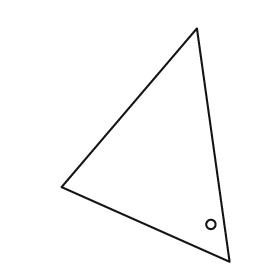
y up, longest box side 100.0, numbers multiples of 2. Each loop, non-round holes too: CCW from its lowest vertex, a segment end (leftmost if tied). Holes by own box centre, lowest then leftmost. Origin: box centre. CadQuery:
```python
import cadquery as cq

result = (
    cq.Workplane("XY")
    .moveTo(36.0, -50.0)
    .lineTo(22.0, 50.0)
    .lineTo(-36.0, -18.0)
    .close()
    .moveTo(28.0, -34.0)
    .circle(2.0)
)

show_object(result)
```